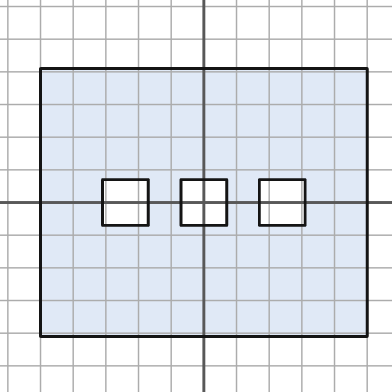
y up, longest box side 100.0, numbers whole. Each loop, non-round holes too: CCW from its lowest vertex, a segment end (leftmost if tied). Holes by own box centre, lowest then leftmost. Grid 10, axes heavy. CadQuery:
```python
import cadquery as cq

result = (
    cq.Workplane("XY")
    .moveTo(-50.0, -41.0)
    .lineTo(50.0, -41.0)
    .lineTo(50.0, 41.0)
    .lineTo(-50.0, 41.0)
    .close()
    .moveTo(-31.0, -7.0)
    .lineTo(-17.0, -7.0)
    .lineTo(-17.0, 7.0)
    .lineTo(-31.0, 7.0)
    .close()
    .moveTo(-7.0, -7.0)
    .lineTo(7.0, -7.0)
    .lineTo(7.0, 7.0)
    .lineTo(-7.0, 7.0)
    .close()
    .moveTo(17.0, -7.0)
    .lineTo(31.0, -7.0)
    .lineTo(31.0, 7.0)
    .lineTo(17.0, 7.0)
    .close()
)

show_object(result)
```